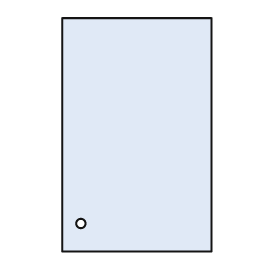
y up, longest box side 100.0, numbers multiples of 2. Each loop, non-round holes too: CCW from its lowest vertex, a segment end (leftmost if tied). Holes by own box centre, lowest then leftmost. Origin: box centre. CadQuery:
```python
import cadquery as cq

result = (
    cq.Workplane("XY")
    .moveTo(-32.0, -50.0)
    .lineTo(32.0, -50.0)
    .lineTo(32.0, 50.0)
    .lineTo(-32.0, 50.0)
    .close()
    .moveTo(-24.0, -38.0)
    .circle(2.0)
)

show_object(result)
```